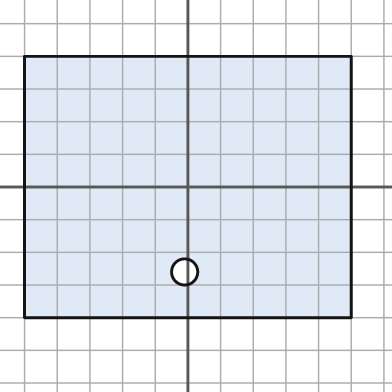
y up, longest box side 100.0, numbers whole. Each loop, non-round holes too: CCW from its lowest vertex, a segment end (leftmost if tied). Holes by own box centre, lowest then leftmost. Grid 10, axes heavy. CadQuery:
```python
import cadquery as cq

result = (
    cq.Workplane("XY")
    .moveTo(-50.0, -40.0)
    .lineTo(50.0, -40.0)
    .lineTo(50.0, 40.0)
    .lineTo(-50.0, 40.0)
    .close()
    .moveTo(-1.0, -26.0)
    .circle(4.0)
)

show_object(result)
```